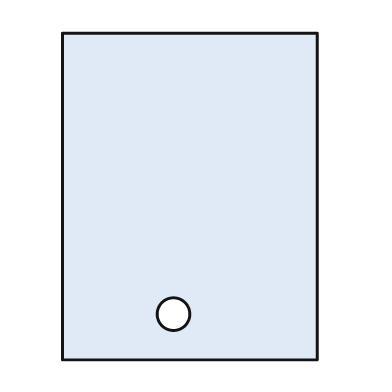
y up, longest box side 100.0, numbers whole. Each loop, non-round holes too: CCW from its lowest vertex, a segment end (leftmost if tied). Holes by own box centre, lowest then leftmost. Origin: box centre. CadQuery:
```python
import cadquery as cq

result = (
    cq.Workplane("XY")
    .moveTo(-39.0, -50.0)
    .lineTo(39.0, -50.0)
    .lineTo(39.0, 50.0)
    .lineTo(-39.0, 50.0)
    .close()
    .moveTo(-5.0, -36.0)
    .circle(5.0)
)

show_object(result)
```